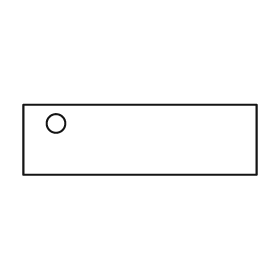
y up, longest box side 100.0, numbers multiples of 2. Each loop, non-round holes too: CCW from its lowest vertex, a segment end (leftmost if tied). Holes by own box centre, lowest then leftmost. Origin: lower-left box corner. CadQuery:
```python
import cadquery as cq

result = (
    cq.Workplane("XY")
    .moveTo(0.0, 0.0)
    .lineTo(100.0, 0.0)
    .lineTo(100.0, 30.0)
    .lineTo(0.0, 30.0)
    .close()
    .moveTo(14.0, 22.0)
    .circle(4.0)
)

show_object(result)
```